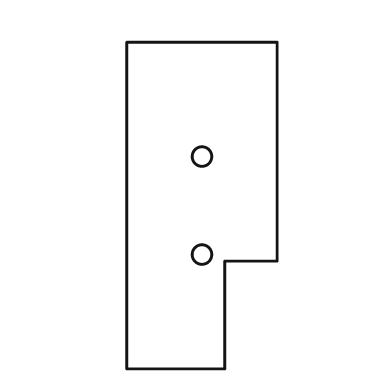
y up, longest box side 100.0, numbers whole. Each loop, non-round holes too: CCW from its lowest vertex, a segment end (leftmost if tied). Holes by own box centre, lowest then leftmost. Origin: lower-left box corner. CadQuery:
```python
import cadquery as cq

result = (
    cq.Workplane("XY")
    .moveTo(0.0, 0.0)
    .lineTo(30.0, 0.0)
    .lineTo(30.0, 33.0)
    .lineTo(46.0, 33.0)
    .lineTo(46.0, 100.0)
    .lineTo(0.0, 100.0)
    .close()
    .moveTo(23.0, 35.0)
    .circle(3.0)
    .moveTo(23.0, 65.0)
    .circle(3.0)
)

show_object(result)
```